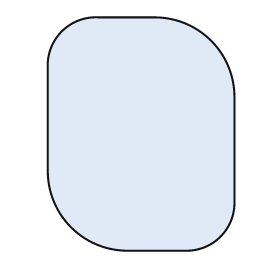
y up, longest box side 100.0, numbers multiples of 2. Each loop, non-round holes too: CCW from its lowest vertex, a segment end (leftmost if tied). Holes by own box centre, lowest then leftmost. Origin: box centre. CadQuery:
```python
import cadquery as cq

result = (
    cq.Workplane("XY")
    .moveTo(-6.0, -50.0)
    .lineTo(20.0, -50.0)
    .threePointArc((34.0, -44.0), (40.0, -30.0))
    .lineTo(40.0, 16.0)
    .threePointArc((30.0, 40.0), (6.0, 50.0))
    .lineTo(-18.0, 50.0)
    .threePointArc((-34.0, 44.0), (-40.0, 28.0))
    .lineTo(-40.0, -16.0)
    .threePointArc((-30.0, -40.0), (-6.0, -50.0))
    .close()
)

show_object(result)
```